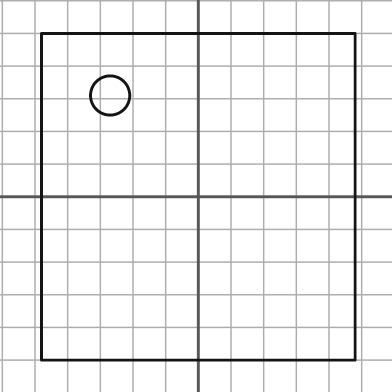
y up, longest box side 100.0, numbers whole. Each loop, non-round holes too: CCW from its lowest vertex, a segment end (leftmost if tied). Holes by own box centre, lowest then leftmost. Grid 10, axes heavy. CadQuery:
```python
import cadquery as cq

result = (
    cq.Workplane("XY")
    .moveTo(-48.0, -50.0)
    .lineTo(48.0, -50.0)
    .lineTo(48.0, 50.0)
    .lineTo(-48.0, 50.0)
    .close()
    .moveTo(-27.0, 31.0)
    .circle(6.0)
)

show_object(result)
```